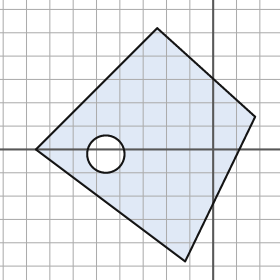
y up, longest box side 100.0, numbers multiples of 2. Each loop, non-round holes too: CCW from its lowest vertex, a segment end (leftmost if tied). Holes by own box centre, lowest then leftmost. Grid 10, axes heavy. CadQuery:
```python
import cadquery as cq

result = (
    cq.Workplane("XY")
    .moveTo(-12.0, -48.0)
    .lineTo(18.0, 14.0)
    .lineTo(-24.0, 52.0)
    .lineTo(-76.0, 0.0)
    .close()
    .moveTo(-46.0, -2.0)
    .circle(8.0)
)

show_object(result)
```